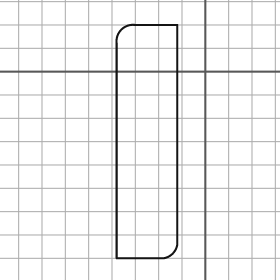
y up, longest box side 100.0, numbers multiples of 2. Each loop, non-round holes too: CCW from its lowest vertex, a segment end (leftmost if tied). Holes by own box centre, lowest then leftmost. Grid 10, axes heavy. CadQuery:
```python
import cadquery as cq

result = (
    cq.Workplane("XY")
    .moveTo(-38.0, -80.0)
    .lineTo(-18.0, -80.0)
    .threePointArc((-14.0, -78.0), (-12.0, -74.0))
    .lineTo(-12.0, 20.0)
    .lineTo(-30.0, 20.0)
    .threePointArc((-36.0, 18.0), (-38.0, 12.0))
    .close()
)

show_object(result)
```